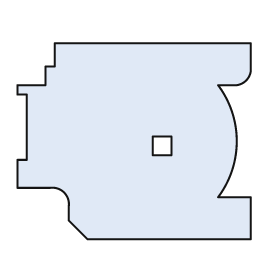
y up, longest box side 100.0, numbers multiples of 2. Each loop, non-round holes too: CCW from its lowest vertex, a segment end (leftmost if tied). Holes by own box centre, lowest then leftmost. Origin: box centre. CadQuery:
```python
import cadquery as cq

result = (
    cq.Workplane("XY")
    .moveTo(-20.0, -42.0)
    .lineTo(50.0, -42.0)
    .lineTo(50.0, -24.0)
    .lineTo(36.0, -24.0)
    .threePointArc((44.0, 0.0), (36.0, 24.0))
    .lineTo(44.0, 24.0)
    .threePointArc((48.0, 26.0), (50.0, 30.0))
    .lineTo(50.0, 42.0)
    .lineTo(-34.0, 42.0)
    .lineTo(-34.0, 32.0)
    .lineTo(-38.0, 32.0)
    .lineTo(-38.0, 24.0)
    .lineTo(-50.0, 24.0)
    .lineTo(-50.0, 20.0)
    .lineTo(-46.0, 20.0)
    .lineTo(-46.0, -8.0)
    .lineTo(-50.0, -8.0)
    .lineTo(-50.0, -20.0)
    .lineTo(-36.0, -20.0)
    .threePointArc((-30.0, -22.0), (-28.0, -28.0))
    .lineTo(-28.0, -34.0)
    .close()
    .moveTo(8.0, -6.0)
    .lineTo(16.0, -6.0)
    .lineTo(16.0, 2.0)
    .lineTo(8.0, 2.0)
    .close()
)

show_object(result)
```